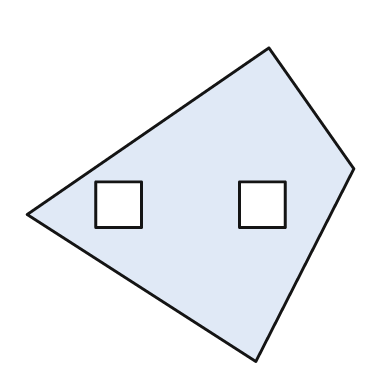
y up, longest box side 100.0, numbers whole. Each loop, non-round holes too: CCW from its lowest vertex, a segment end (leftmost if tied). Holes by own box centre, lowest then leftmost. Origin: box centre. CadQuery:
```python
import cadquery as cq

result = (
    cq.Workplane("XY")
    .moveTo(20.0, -48.0)
    .lineTo(50.0, 11.0)
    .lineTo(24.0, 48.0)
    .lineTo(-50.0, -3.0)
    .close()
    .moveTo(-29.0, -7.0)
    .lineTo(-15.0, -7.0)
    .lineTo(-15.0, 7.0)
    .lineTo(-29.0, 7.0)
    .close()
    .moveTo(15.0, -7.0)
    .lineTo(29.0, -7.0)
    .lineTo(29.0, 7.0)
    .lineTo(15.0, 7.0)
    .close()
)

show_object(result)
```